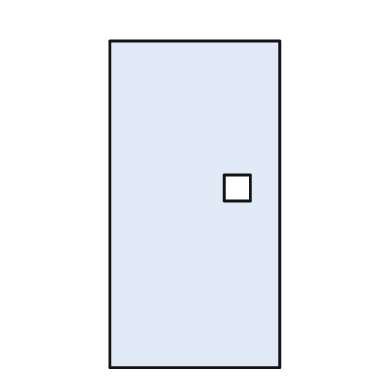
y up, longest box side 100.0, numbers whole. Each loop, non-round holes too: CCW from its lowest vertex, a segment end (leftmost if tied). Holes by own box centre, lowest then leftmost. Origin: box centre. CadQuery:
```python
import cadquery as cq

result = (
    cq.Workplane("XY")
    .moveTo(-26.0, -50.0)
    .lineTo(26.0, -50.0)
    .lineTo(26.0, 50.0)
    .lineTo(-26.0, 50.0)
    .close()
    .moveTo(9.0, 1.0)
    .lineTo(17.0, 1.0)
    .lineTo(17.0, 9.0)
    .lineTo(9.0, 9.0)
    .close()
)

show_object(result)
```